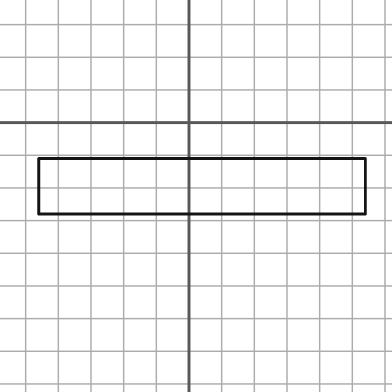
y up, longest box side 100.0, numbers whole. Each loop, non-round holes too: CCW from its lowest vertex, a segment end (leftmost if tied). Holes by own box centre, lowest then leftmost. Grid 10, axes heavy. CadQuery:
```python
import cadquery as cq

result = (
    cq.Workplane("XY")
    .moveTo(-46.0, -28.0)
    .lineTo(54.0, -28.0)
    .lineTo(54.0, -11.0)
    .lineTo(-46.0, -11.0)
    .close()
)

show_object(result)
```